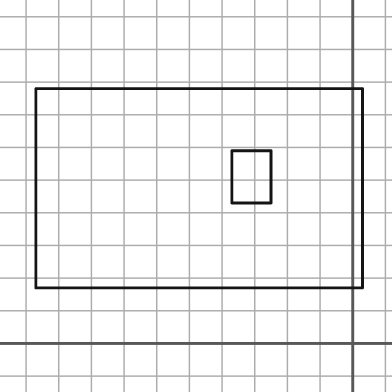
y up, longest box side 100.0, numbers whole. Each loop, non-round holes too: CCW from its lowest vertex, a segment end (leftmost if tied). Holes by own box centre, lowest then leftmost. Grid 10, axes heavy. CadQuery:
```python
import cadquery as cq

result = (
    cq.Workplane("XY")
    .moveTo(-97.0, 17.0)
    .lineTo(3.0, 17.0)
    .lineTo(3.0, 78.0)
    .lineTo(-97.0, 78.0)
    .close()
    .moveTo(-37.0, 43.0)
    .lineTo(-25.0, 43.0)
    .lineTo(-25.0, 59.0)
    .lineTo(-37.0, 59.0)
    .close()
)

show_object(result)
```